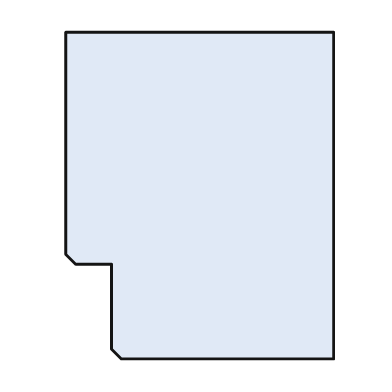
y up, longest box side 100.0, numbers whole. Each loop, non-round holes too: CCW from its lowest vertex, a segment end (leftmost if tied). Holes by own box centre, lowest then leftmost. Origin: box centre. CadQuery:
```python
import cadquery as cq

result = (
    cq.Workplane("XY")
    .moveTo(-24.0, -50.0)
    .lineTo(41.0, -50.0)
    .lineTo(41.0, 50.0)
    .lineTo(-41.0, 50.0)
    .lineTo(-41.0, -18.0)
    .lineTo(-38.0, -21.0)
    .lineTo(-27.0, -21.0)
    .lineTo(-27.0, -47.0)
    .close()
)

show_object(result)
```